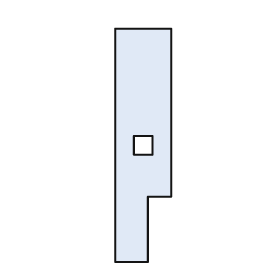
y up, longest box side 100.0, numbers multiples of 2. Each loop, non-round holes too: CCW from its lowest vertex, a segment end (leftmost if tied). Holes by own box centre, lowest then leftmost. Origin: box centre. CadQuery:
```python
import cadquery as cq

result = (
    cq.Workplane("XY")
    .moveTo(-12.0, -50.0)
    .lineTo(2.0, -50.0)
    .lineTo(2.0, -22.0)
    .lineTo(12.0, -22.0)
    .lineTo(12.0, 50.0)
    .lineTo(-12.0, 50.0)
    .close()
    .moveTo(-4.0, -4.0)
    .lineTo(4.0, -4.0)
    .lineTo(4.0, 4.0)
    .lineTo(-4.0, 4.0)
    .close()
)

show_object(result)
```